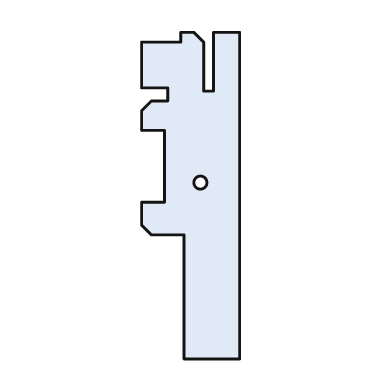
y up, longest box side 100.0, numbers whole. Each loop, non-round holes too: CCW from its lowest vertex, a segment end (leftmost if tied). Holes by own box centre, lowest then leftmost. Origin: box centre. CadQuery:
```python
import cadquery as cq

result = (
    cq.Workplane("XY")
    .moveTo(-2.0, -50.0)
    .lineTo(15.0, -50.0)
    .lineTo(15.0, 50.0)
    .lineTo(7.0, 50.0)
    .lineTo(7.0, 32.0)
    .lineTo(4.0, 32.0)
    .lineTo(4.0, 47.0)
    .lineTo(1.0, 50.0)
    .lineTo(-3.0, 50.0)
    .lineTo(-3.0, 47.0)
    .lineTo(-15.0, 47.0)
    .lineTo(-15.0, 33.0)
    .lineTo(-7.0, 33.0)
    .lineTo(-7.0, 29.0)
    .lineTo(-12.0, 29.0)
    .lineTo(-15.0, 26.0)
    .lineTo(-15.0, 20.0)
    .lineTo(-8.0, 20.0)
    .lineTo(-8.0, -2.0)
    .lineTo(-15.0, -2.0)
    .lineTo(-15.0, -9.0)
    .lineTo(-12.0, -12.0)
    .lineTo(-2.0, -12.0)
    .close()
    .moveTo(3.0, 4.0)
    .circle(2.0)
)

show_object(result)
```